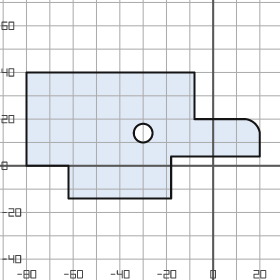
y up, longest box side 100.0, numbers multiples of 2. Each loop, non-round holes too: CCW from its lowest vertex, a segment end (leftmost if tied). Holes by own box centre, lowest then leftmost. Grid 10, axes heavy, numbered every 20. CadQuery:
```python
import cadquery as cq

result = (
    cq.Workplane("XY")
    .moveTo(-62.0, -14.0)
    .lineTo(-18.0, -14.0)
    .lineTo(-18.0, 4.0)
    .lineTo(20.0, 4.0)
    .lineTo(20.0, 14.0)
    .threePointArc((18.0, 18.0), (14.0, 20.0))
    .lineTo(-8.0, 20.0)
    .lineTo(-8.0, 40.0)
    .lineTo(-80.0, 40.0)
    .lineTo(-80.0, 0.0)
    .lineTo(-62.0, 0.0)
    .close()
    .moveTo(-30.0, 14.0)
    .circle(4.0)
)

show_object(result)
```